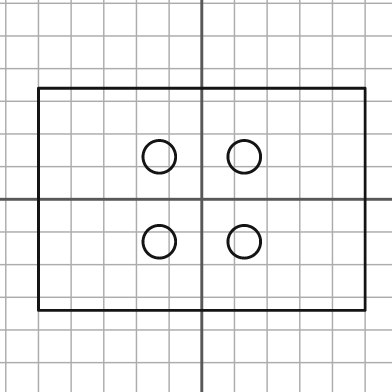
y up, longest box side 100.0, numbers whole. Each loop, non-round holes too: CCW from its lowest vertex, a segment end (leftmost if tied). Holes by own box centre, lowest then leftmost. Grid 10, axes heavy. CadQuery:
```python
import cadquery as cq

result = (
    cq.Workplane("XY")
    .moveTo(-50.0, -34.0)
    .lineTo(50.0, -34.0)
    .lineTo(50.0, 34.0)
    .lineTo(-50.0, 34.0)
    .close()
    .moveTo(-13.0, -13.0)
    .circle(5.0)
    .moveTo(13.0, -13.0)
    .circle(5.0)
    .moveTo(-13.0, 13.0)
    .circle(5.0)
    .moveTo(13.0, 13.0)
    .circle(5.0)
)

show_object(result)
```